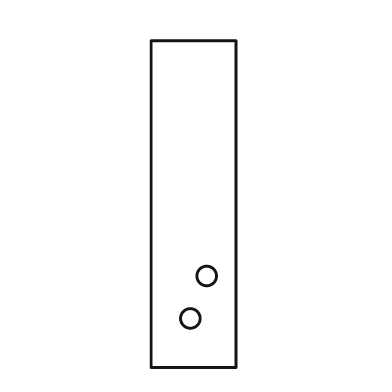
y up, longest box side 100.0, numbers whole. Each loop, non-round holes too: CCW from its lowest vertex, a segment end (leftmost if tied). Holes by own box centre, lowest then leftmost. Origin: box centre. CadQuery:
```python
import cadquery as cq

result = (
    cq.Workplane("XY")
    .moveTo(-13.0, -50.0)
    .lineTo(13.0, -50.0)
    .lineTo(13.0, 50.0)
    .lineTo(-13.0, 50.0)
    .close()
    .moveTo(-1.0, -35.0)
    .circle(3.0)
    .moveTo(4.0, -22.0)
    .circle(3.0)
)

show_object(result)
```